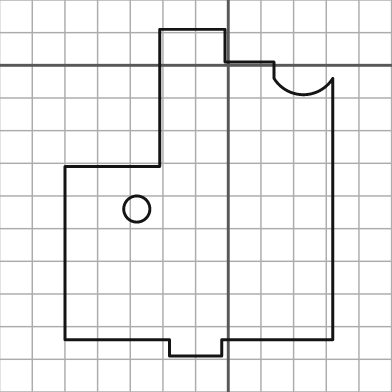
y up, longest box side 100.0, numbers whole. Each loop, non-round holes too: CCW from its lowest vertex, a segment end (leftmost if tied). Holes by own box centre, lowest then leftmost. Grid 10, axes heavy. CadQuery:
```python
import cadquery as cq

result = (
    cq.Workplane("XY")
    .moveTo(-18.0, -89.0)
    .lineTo(-2.0, -89.0)
    .lineTo(-2.0, -84.0)
    .lineTo(32.0, -84.0)
    .lineTo(32.0, -4.0)
    .threePointArc((23.0, -9.0), (14.0, -4.0))
    .lineTo(14.0, 1.0)
    .lineTo(-1.0, 1.0)
    .lineTo(-1.0, 11.0)
    .lineTo(-21.0, 11.0)
    .lineTo(-21.0, -31.0)
    .lineTo(-50.0, -31.0)
    .lineTo(-50.0, -84.0)
    .lineTo(-18.0, -84.0)
    .close()
    .moveTo(-28.0, -44.0)
    .circle(4.0)
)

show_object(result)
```